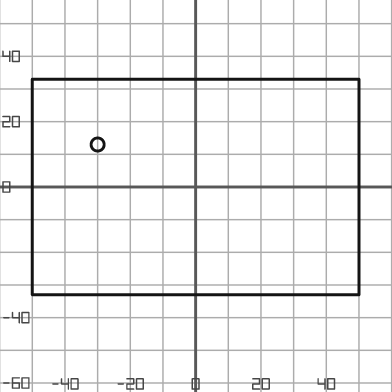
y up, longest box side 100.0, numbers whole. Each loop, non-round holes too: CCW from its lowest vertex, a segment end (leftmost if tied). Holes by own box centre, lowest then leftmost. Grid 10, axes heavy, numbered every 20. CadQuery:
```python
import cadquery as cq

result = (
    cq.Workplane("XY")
    .moveTo(-50.0, -33.0)
    .lineTo(50.0, -33.0)
    .lineTo(50.0, 33.0)
    .lineTo(-50.0, 33.0)
    .close()
    .moveTo(-30.0, 13.0)
    .circle(2.0)
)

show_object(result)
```